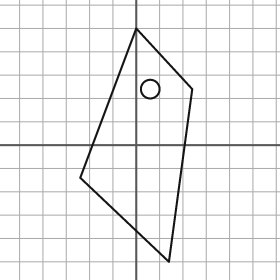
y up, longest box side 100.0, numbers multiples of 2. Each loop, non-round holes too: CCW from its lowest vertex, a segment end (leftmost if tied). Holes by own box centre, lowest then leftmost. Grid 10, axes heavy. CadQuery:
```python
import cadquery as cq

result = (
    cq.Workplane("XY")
    .moveTo(14.0, -50.0)
    .lineTo(24.0, 24.0)
    .lineTo(0.0, 50.0)
    .lineTo(-24.0, -14.0)
    .close()
    .moveTo(6.0, 24.0)
    .circle(4.0)
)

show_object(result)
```